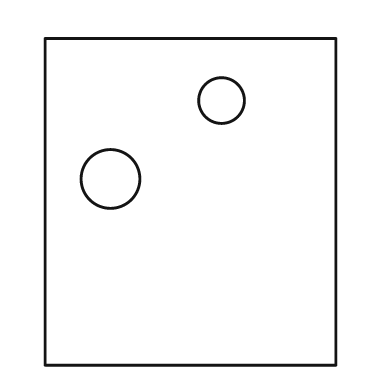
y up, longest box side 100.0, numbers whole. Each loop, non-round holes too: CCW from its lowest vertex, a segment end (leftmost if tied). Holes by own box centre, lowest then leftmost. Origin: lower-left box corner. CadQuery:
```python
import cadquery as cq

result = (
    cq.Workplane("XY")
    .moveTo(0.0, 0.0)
    .lineTo(89.0, 0.0)
    .lineTo(89.0, 100.0)
    .lineTo(0.0, 100.0)
    .close()
    .moveTo(20.0, 57.0)
    .circle(9.0)
    .moveTo(54.0, 81.0)
    .circle(7.0)
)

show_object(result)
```